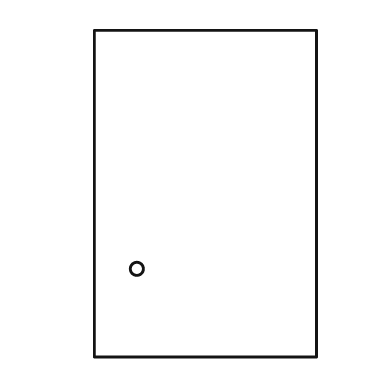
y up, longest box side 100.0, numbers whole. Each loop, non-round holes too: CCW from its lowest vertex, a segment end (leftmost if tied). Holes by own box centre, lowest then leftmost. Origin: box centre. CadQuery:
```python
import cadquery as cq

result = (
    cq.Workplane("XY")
    .moveTo(-34.0, -50.0)
    .lineTo(34.0, -50.0)
    .lineTo(34.0, 50.0)
    .lineTo(-34.0, 50.0)
    .close()
    .moveTo(-21.0, -23.0)
    .circle(2.0)
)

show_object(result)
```